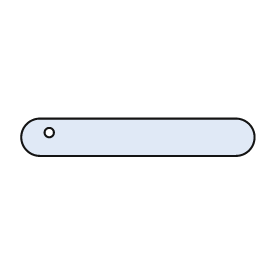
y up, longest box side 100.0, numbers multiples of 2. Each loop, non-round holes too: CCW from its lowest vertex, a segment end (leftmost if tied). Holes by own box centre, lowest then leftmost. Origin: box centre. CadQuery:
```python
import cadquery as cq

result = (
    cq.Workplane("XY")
    .moveTo(-42.0, -8.0)
    .lineTo(42.0, -8.0)
    .threePointArc((50.0, 0.0), (42.0, 8.0))
    .lineTo(-42.0, 8.0)
    .threePointArc((-50.0, 0.0), (-42.0, -8.0))
    .close()
    .moveTo(-38.0, 2.0)
    .circle(2.0)
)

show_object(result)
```